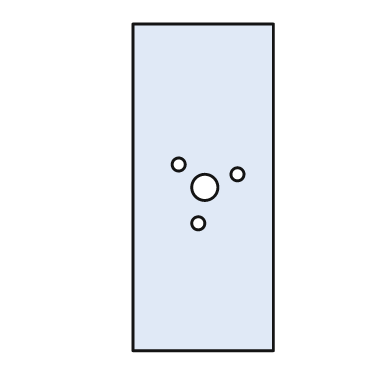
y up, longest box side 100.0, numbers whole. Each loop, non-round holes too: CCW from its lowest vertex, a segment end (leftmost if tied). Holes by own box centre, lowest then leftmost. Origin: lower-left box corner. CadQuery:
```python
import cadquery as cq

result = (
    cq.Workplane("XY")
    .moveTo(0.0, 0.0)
    .lineTo(43.0, 0.0)
    .lineTo(43.0, 100.0)
    .lineTo(0.0, 100.0)
    .close()
    .moveTo(20.0, 39.0)
    .circle(2.0)
    .moveTo(22.0, 50.0)
    .circle(4.0)
    .moveTo(32.0, 54.0)
    .circle(2.0)
    .moveTo(14.0, 57.0)
    .circle(2.0)
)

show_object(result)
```